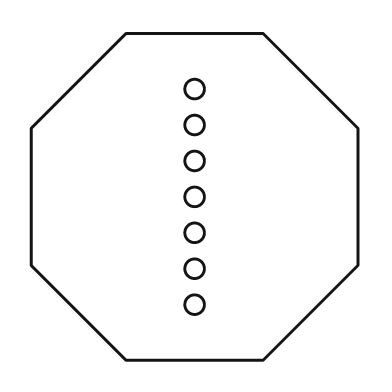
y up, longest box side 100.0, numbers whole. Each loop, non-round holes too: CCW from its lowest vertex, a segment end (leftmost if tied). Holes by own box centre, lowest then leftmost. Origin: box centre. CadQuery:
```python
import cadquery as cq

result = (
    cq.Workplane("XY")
    .moveTo(-21.0, -50.0)
    .lineTo(21.0, -50.0)
    .lineTo(50.0, -21.0)
    .lineTo(50.0, 21.0)
    .lineTo(21.0, 50.0)
    .lineTo(-21.0, 50.0)
    .lineTo(-50.0, 21.0)
    .lineTo(-50.0, -21.0)
    .close()
    .moveTo(0.0, -33.0)
    .circle(3.0)
    .moveTo(0.0, -22.0)
    .circle(3.0)
    .moveTo(0.0, -11.0)
    .circle(3.0)
    .moveTo(0.0, 0.0)
    .circle(3.0)
    .moveTo(0.0, 11.0)
    .circle(3.0)
    .moveTo(0.0, 22.0)
    .circle(3.0)
    .moveTo(0.0, 33.0)
    .circle(3.0)
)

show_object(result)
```